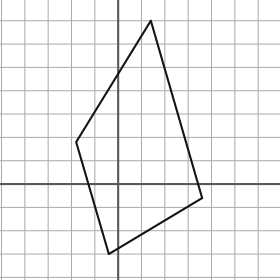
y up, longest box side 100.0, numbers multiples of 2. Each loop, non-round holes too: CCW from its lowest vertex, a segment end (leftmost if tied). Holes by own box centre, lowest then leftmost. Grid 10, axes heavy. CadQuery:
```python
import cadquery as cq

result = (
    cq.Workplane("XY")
    .moveTo(-4.0, -30.0)
    .lineTo(36.0, -6.0)
    .lineTo(14.0, 70.0)
    .lineTo(-18.0, 18.0)
    .close()
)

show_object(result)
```